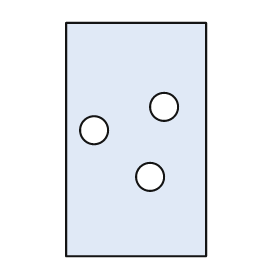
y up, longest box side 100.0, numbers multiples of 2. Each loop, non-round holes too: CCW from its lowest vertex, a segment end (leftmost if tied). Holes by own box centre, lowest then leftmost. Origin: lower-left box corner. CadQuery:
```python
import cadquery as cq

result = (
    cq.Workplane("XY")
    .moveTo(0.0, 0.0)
    .lineTo(60.0, 0.0)
    .lineTo(60.0, 100.0)
    .lineTo(0.0, 100.0)
    .close()
    .moveTo(36.0, 34.0)
    .circle(6.0)
    .moveTo(12.0, 54.0)
    .circle(6.0)
    .moveTo(42.0, 64.0)
    .circle(6.0)
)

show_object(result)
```